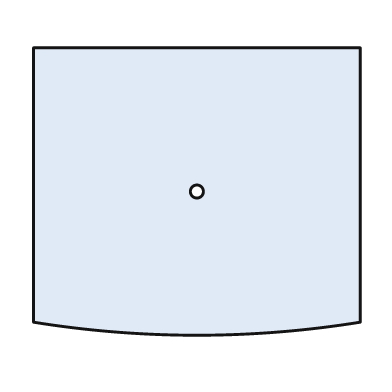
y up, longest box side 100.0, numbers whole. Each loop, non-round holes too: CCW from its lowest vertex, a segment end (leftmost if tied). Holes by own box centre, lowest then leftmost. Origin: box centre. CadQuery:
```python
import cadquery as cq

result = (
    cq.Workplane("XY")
    .moveTo(-50.0, -40.0)
    .threePointArc((0.0, -44.0), (50.0, -40.0))
    .lineTo(50.0, 44.0)
    .lineTo(-50.0, 44.0)
    .close()
    .moveTo(0.0, 0.0)
    .circle(2.0)
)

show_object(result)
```